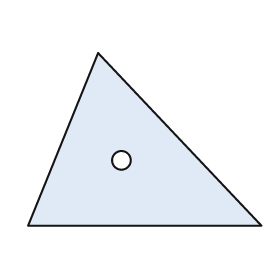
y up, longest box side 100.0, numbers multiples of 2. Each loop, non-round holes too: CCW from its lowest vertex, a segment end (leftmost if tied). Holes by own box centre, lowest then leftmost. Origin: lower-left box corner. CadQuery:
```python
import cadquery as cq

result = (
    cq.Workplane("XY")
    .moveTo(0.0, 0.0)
    .lineTo(100.0, 0.0)
    .lineTo(30.0, 74.0)
    .close()
    .moveTo(40.0, 28.0)
    .circle(4.0)
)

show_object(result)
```